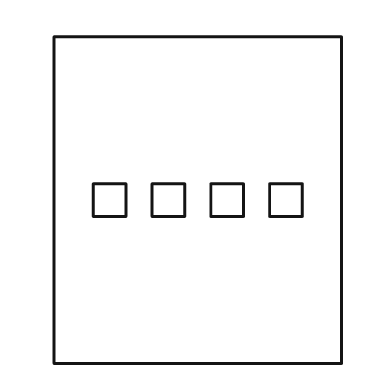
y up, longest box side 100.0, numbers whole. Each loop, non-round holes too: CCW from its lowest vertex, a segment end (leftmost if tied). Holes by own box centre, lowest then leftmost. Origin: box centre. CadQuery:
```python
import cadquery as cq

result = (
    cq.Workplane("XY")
    .moveTo(-44.0, -50.0)
    .lineTo(44.0, -50.0)
    .lineTo(44.0, 50.0)
    .lineTo(-44.0, 50.0)
    .close()
    .moveTo(-32.0, -5.0)
    .lineTo(-22.0, -5.0)
    .lineTo(-22.0, 5.0)
    .lineTo(-32.0, 5.0)
    .close()
    .moveTo(-14.0, -5.0)
    .lineTo(-4.0, -5.0)
    .lineTo(-4.0, 5.0)
    .lineTo(-14.0, 5.0)
    .close()
    .moveTo(4.0, -5.0)
    .lineTo(14.0, -5.0)
    .lineTo(14.0, 5.0)
    .lineTo(4.0, 5.0)
    .close()
    .moveTo(22.0, -5.0)
    .lineTo(32.0, -5.0)
    .lineTo(32.0, 5.0)
    .lineTo(22.0, 5.0)
    .close()
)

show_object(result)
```